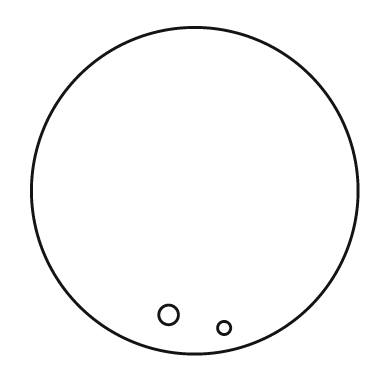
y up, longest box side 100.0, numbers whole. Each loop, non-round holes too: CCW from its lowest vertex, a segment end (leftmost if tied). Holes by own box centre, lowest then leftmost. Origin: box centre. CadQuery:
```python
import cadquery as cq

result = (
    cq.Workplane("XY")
    .moveTo(0.0, 0.0)
    .circle(50.0)
    .moveTo(9.0, -42.0)
    .circle(2.0)
    .moveTo(-8.0, -38.0)
    .circle(3.0)
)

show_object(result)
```